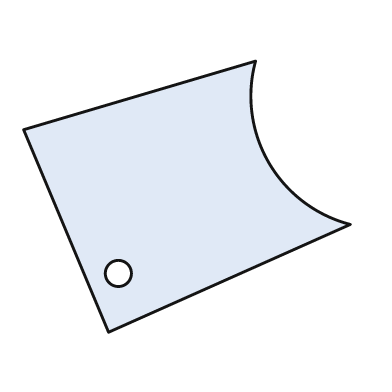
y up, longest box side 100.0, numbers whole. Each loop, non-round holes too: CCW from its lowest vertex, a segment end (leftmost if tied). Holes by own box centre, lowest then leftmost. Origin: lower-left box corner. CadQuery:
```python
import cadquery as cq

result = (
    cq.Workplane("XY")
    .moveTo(26.0, 0.0)
    .lineTo(100.0, 33.0)
    .threePointArc((75.0, 52.0), (71.0, 83.0))
    .lineTo(0.0, 62.0)
    .close()
    .moveTo(29.0, 18.0)
    .circle(4.0)
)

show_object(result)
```